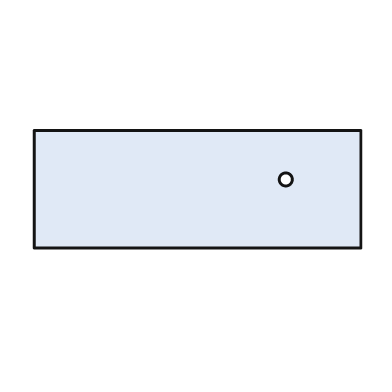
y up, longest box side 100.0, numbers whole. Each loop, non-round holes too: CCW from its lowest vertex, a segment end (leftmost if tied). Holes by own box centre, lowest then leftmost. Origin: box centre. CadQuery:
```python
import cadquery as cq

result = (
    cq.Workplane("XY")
    .moveTo(-50.0, -18.0)
    .lineTo(50.0, -18.0)
    .lineTo(50.0, 18.0)
    .lineTo(-50.0, 18.0)
    .close()
    .moveTo(27.0, 3.0)
    .circle(2.0)
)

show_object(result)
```